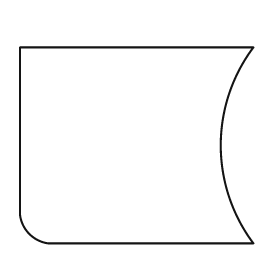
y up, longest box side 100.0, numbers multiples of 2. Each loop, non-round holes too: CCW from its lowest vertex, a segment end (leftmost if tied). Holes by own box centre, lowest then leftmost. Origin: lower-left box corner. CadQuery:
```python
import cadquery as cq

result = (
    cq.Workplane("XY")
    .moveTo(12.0, 0.0)
    .lineTo(100.0, 0.0)
    .threePointArc((86.0, 42.0), (100.0, 84.0))
    .lineTo(0.0, 84.0)
    .lineTo(0.0, 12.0)
    .threePointArc((4.0, 4.0), (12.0, 0.0))
    .close()
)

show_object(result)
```